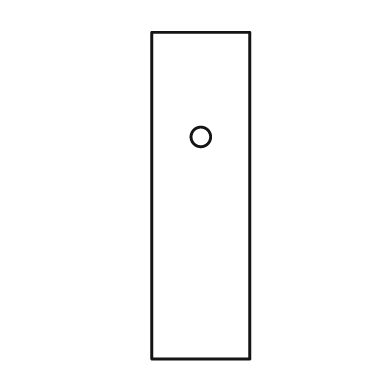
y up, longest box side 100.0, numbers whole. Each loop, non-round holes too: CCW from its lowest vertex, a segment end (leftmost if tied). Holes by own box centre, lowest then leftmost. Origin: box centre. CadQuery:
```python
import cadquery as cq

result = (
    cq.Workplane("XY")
    .moveTo(-15.0, -50.0)
    .lineTo(15.0, -50.0)
    .lineTo(15.0, 50.0)
    .lineTo(-15.0, 50.0)
    .close()
    .moveTo(0.0, 18.0)
    .circle(3.0)
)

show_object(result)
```